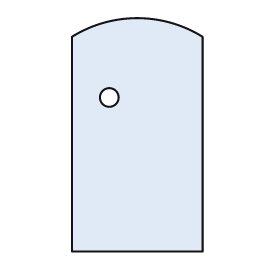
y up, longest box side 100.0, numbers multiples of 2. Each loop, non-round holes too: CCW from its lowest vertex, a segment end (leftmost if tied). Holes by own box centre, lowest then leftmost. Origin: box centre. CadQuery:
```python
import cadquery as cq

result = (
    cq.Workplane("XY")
    .moveTo(-28.0, -50.0)
    .lineTo(28.0, -50.0)
    .lineTo(28.0, 42.0)
    .threePointArc((0.0, 50.0), (-28.0, 42.0))
    .close()
    .moveTo(-12.0, 16.0)
    .circle(4.0)
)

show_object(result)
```